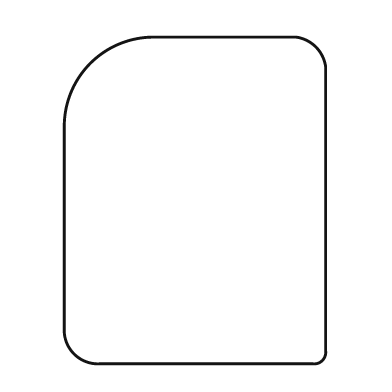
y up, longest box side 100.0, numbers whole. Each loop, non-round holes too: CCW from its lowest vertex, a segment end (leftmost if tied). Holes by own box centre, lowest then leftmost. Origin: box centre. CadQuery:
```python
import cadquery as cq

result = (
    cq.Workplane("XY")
    .moveTo(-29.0, -50.0)
    .lineTo(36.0, -50.0)
    .threePointArc((39.0, -49.0), (40.0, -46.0))
    .lineTo(40.0, 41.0)
    .threePointArc((37.0, 47.0), (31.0, 50.0))
    .lineTo(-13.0, 50.0)
    .threePointArc((-32.0, 42.0), (-40.0, 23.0))
    .lineTo(-40.0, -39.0)
    .threePointArc((-37.0, -47.0), (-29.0, -50.0))
    .close()
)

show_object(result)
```